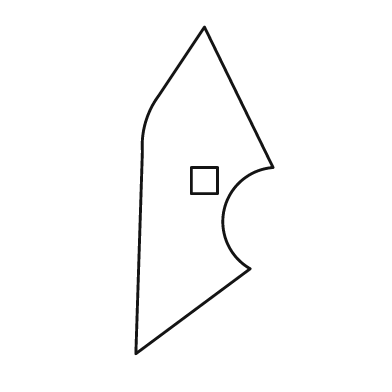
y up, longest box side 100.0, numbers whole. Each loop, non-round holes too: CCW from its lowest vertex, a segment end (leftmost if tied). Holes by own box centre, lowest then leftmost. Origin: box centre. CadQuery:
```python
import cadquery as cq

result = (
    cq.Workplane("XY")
    .moveTo(-21.0, -50.0)
    .lineTo(14.0, -24.0)
    .threePointArc((6.0, -6.0), (21.0, 7.0))
    .lineTo(0.0, 50.0)
    .lineTo(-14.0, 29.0)
    .threePointArc((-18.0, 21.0), (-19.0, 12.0))
    .close()
    .moveTo(-4.0, -1.0)
    .lineTo(4.0, -1.0)
    .lineTo(4.0, 7.0)
    .lineTo(-4.0, 7.0)
    .close()
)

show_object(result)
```